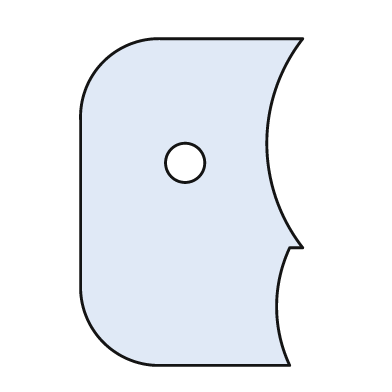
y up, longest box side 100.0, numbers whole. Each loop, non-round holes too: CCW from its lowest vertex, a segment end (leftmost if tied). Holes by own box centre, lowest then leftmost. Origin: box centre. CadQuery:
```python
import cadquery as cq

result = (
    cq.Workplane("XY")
    .moveTo(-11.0, -50.0)
    .lineTo(30.0, -50.0)
    .threePointArc((26.0, -32.0), (30.0, -14.0))
    .lineTo(34.0, -14.0)
    .threePointArc((23.0, 18.0), (34.0, 50.0))
    .lineTo(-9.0, 50.0)
    .threePointArc((-27.0, 43.0), (-34.0, 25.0))
    .lineTo(-34.0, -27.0)
    .threePointArc((-27.0, -43.0), (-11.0, -50.0))
    .close()
    .moveTo(-2.0, 12.0)
    .circle(6.0)
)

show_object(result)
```